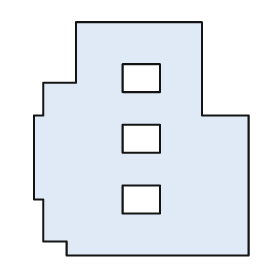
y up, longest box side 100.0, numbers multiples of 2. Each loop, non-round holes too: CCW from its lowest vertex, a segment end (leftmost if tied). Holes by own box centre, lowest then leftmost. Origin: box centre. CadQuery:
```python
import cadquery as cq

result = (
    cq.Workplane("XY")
    .moveTo(-32.0, -50.0)
    .lineTo(46.0, -50.0)
    .lineTo(46.0, 10.0)
    .lineTo(26.0, 10.0)
    .lineTo(26.0, 50.0)
    .lineTo(-28.0, 50.0)
    .lineTo(-28.0, 24.0)
    .lineTo(-42.0, 24.0)
    .lineTo(-42.0, 10.0)
    .lineTo(-46.0, 10.0)
    .lineTo(-46.0, -26.0)
    .lineTo(-42.0, -26.0)
    .lineTo(-42.0, -44.0)
    .lineTo(-32.0, -44.0)
    .close()
    .moveTo(-8.0, -32.0)
    .lineTo(8.0, -32.0)
    .lineTo(8.0, -20.0)
    .lineTo(-8.0, -20.0)
    .close()
    .moveTo(-8.0, -6.0)
    .lineTo(8.0, -6.0)
    .lineTo(8.0, 6.0)
    .lineTo(-8.0, 6.0)
    .close()
    .moveTo(-8.0, 20.0)
    .lineTo(8.0, 20.0)
    .lineTo(8.0, 32.0)
    .lineTo(-8.0, 32.0)
    .close()
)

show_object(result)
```